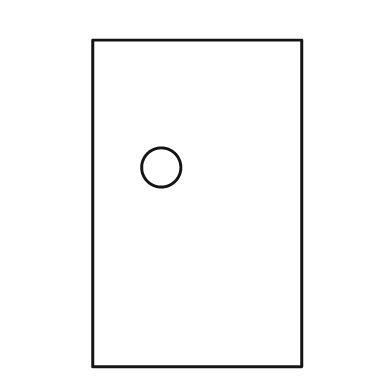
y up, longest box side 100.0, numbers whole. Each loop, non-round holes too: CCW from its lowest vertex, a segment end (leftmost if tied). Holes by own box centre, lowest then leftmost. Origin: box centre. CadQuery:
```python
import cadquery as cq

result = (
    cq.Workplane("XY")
    .moveTo(-32.0, -50.0)
    .lineTo(32.0, -50.0)
    .lineTo(32.0, 50.0)
    .lineTo(-32.0, 50.0)
    .close()
    .moveTo(-11.0, 11.0)
    .circle(6.0)
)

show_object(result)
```